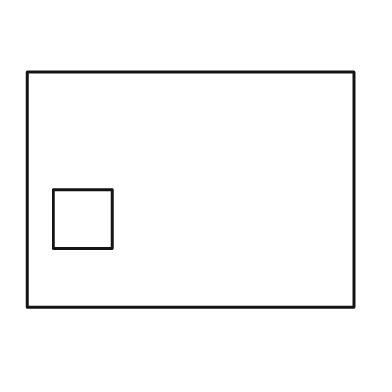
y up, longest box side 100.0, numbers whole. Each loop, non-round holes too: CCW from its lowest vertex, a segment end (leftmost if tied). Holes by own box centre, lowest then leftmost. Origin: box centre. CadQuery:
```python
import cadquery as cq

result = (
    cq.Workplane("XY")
    .moveTo(-50.0, -36.0)
    .lineTo(50.0, -36.0)
    .lineTo(50.0, 36.0)
    .lineTo(-50.0, 36.0)
    .close()
    .moveTo(-42.0, -18.0)
    .lineTo(-24.0, -18.0)
    .lineTo(-24.0, 0.0)
    .lineTo(-42.0, 0.0)
    .close()
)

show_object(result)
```